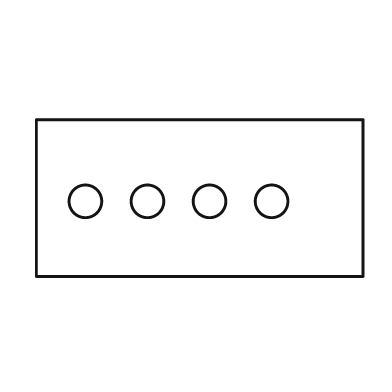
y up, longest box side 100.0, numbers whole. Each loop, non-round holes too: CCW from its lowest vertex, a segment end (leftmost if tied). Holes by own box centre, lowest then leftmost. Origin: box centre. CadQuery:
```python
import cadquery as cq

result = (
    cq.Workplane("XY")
    .moveTo(-50.0, -24.0)
    .lineTo(50.0, -24.0)
    .lineTo(50.0, 24.0)
    .lineTo(-50.0, 24.0)
    .close()
    .moveTo(-35.0, -1.0)
    .circle(5.0)
    .moveTo(-16.0, -1.0)
    .circle(5.0)
    .moveTo(3.0, -1.0)
    .circle(5.0)
    .moveTo(22.0, -1.0)
    .circle(5.0)
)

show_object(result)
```